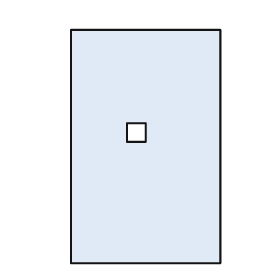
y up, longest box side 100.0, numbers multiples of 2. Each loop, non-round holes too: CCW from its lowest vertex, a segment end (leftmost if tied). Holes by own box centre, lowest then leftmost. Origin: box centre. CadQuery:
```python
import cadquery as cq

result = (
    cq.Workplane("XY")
    .moveTo(-32.0, -50.0)
    .lineTo(32.0, -50.0)
    .lineTo(32.0, 50.0)
    .lineTo(-32.0, 50.0)
    .close()
    .moveTo(-8.0, 2.0)
    .lineTo(0.0, 2.0)
    .lineTo(0.0, 10.0)
    .lineTo(-8.0, 10.0)
    .close()
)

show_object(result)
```